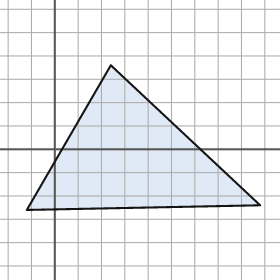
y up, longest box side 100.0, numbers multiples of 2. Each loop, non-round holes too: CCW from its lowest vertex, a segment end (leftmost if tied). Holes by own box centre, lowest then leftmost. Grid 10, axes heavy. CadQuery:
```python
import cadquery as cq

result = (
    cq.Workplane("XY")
    .moveTo(-12.0, -26.0)
    .lineTo(88.0, -24.0)
    .lineTo(24.0, 36.0)
    .close()
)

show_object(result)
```